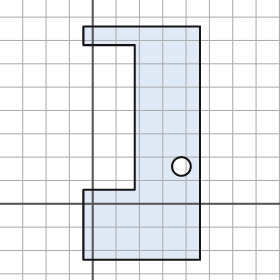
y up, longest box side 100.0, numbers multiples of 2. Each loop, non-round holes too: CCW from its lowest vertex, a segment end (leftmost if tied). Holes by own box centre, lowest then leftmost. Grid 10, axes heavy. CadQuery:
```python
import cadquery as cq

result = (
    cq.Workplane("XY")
    .moveTo(-4.0, -24.0)
    .lineTo(46.0, -24.0)
    .lineTo(46.0, 76.0)
    .lineTo(-4.0, 76.0)
    .lineTo(-4.0, 68.0)
    .lineTo(18.0, 68.0)
    .lineTo(18.0, 6.0)
    .lineTo(-4.0, 6.0)
    .close()
    .moveTo(38.0, 16.0)
    .circle(4.0)
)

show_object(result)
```